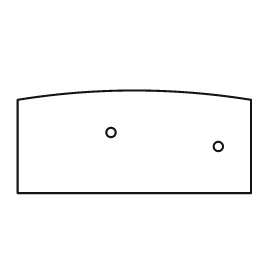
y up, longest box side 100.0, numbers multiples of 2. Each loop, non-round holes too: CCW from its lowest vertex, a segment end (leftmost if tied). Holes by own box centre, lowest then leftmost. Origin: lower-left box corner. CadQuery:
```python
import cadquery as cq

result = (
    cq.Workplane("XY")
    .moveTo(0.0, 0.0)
    .lineTo(100.0, 0.0)
    .lineTo(100.0, 40.0)
    .threePointArc((50.0, 44.0), (0.0, 40.0))
    .close()
    .moveTo(86.0, 20.0)
    .circle(2.0)
    .moveTo(40.0, 26.0)
    .circle(2.0)
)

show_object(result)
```